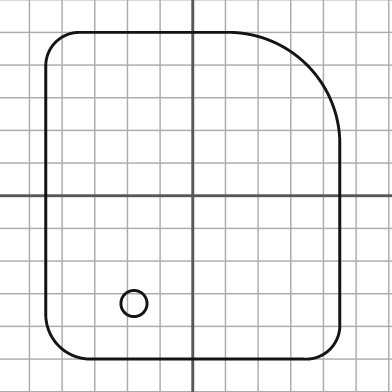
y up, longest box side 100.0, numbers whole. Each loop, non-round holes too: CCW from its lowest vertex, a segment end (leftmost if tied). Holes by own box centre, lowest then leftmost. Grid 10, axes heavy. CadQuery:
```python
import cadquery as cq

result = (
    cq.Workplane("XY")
    .moveTo(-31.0, -50.0)
    .lineTo(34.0, -50.0)
    .threePointArc((42.0, -47.0), (45.0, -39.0))
    .lineTo(45.0, 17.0)
    .threePointArc((35.0, 40.0), (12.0, 50.0))
    .lineTo(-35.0, 50.0)
    .threePointArc((-42.0, 47.0), (-45.0, 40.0))
    .lineTo(-45.0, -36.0)
    .threePointArc((-41.0, -46.0), (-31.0, -50.0))
    .close()
    .moveTo(-18.0, -33.0)
    .circle(4.0)
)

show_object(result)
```